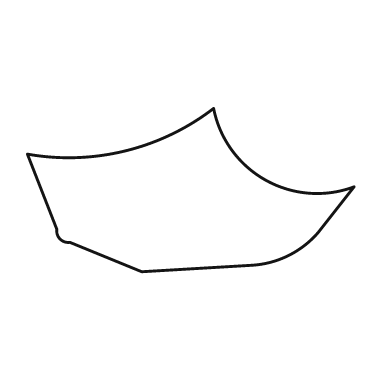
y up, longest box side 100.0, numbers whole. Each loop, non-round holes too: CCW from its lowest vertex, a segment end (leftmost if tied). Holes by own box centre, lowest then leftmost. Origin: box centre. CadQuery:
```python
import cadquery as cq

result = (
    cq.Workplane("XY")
    .moveTo(-15.0, -25.0)
    .lineTo(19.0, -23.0)
    .threePointArc((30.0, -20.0), (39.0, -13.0))
    .lineTo(50.0, 1.0)
    .threePointArc((23.0, 3.0), (7.0, 25.0))
    .threePointArc((-20.0, 12.0), (-50.0, 11.0))
    .lineTo(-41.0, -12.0)
    .threePointArc((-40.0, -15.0), (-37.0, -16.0))
    .close()
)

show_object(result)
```